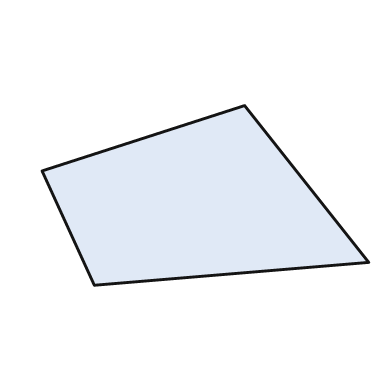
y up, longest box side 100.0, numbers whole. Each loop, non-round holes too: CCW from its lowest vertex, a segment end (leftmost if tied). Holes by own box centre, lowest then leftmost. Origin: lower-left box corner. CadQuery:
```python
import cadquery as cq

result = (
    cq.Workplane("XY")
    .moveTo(16.0, 0.0)
    .lineTo(100.0, 7.0)
    .lineTo(62.0, 55.0)
    .lineTo(0.0, 35.0)
    .close()
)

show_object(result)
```